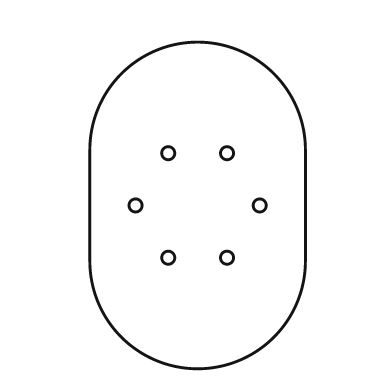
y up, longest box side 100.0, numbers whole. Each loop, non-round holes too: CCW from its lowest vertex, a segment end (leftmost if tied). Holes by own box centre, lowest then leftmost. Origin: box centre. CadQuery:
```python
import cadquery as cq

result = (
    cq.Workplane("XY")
    .moveTo(-33.0, -17.0)
    .threePointArc((0.0, -50.0), (33.0, -17.0))
    .lineTo(33.0, 17.0)
    .threePointArc((0.0, 50.0), (-33.0, 17.0))
    .close()
    .moveTo(-9.0, -16.0)
    .circle(2.0)
    .moveTo(9.0, -16.0)
    .circle(2.0)
    .moveTo(-19.0, 0.0)
    .circle(2.0)
    .moveTo(19.0, 0.0)
    .circle(2.0)
    .moveTo(-9.0, 16.0)
    .circle(2.0)
    .moveTo(9.0, 16.0)
    .circle(2.0)
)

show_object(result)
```